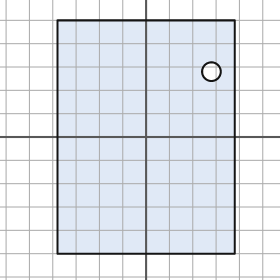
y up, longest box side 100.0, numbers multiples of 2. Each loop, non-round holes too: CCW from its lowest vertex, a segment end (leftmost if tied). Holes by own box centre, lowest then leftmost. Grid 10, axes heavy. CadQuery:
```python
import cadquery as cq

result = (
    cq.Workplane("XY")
    .moveTo(-38.0, -50.0)
    .lineTo(38.0, -50.0)
    .lineTo(38.0, 50.0)
    .lineTo(-38.0, 50.0)
    .close()
    .moveTo(28.0, 28.0)
    .circle(4.0)
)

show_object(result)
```